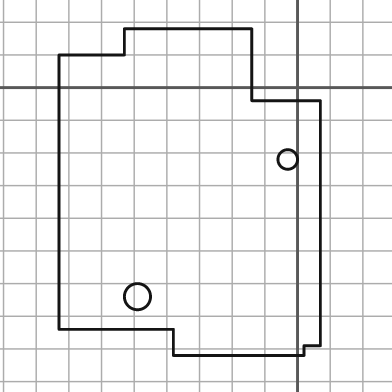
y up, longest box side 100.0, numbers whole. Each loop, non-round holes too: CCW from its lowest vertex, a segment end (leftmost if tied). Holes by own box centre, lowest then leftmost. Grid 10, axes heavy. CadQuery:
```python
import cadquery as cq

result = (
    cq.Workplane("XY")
    .moveTo(-38.0, -82.0)
    .lineTo(2.0, -82.0)
    .lineTo(2.0, -79.0)
    .lineTo(7.0, -79.0)
    .lineTo(7.0, -4.0)
    .lineTo(-14.0, -4.0)
    .lineTo(-14.0, 18.0)
    .lineTo(-53.0, 18.0)
    .lineTo(-53.0, 10.0)
    .lineTo(-73.0, 10.0)
    .lineTo(-73.0, -74.0)
    .lineTo(-38.0, -74.0)
    .close()
    .moveTo(-49.0, -64.0)
    .circle(4.0)
    .moveTo(-3.0, -22.0)
    .circle(3.0)
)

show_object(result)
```